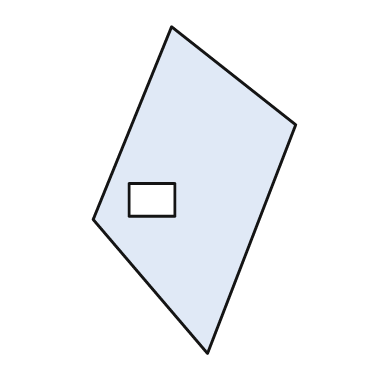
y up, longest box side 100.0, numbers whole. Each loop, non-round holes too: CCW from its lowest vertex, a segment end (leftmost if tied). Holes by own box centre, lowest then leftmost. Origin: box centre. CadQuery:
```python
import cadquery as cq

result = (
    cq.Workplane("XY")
    .moveTo(4.0, -50.0)
    .lineTo(31.0, 20.0)
    .lineTo(-7.0, 50.0)
    .lineTo(-31.0, -9.0)
    .close()
    .moveTo(-20.0, -8.0)
    .lineTo(-6.0, -8.0)
    .lineTo(-6.0, 2.0)
    .lineTo(-20.0, 2.0)
    .close()
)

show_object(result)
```